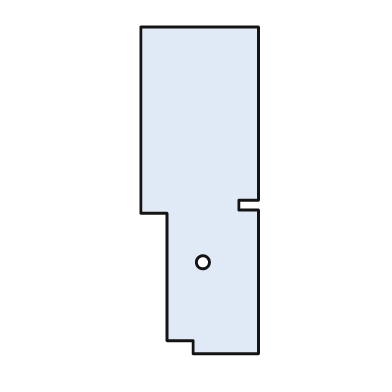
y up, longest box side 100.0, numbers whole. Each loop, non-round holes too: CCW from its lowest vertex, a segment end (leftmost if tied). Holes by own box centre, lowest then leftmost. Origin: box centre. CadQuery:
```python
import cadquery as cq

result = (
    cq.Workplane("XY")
    .moveTo(-2.0, -50.0)
    .lineTo(18.0, -50.0)
    .lineTo(18.0, -6.0)
    .lineTo(12.0, -6.0)
    .lineTo(12.0, -3.0)
    .lineTo(18.0, -3.0)
    .lineTo(18.0, 50.0)
    .lineTo(-18.0, 50.0)
    .lineTo(-18.0, -7.0)
    .lineTo(-10.0, -7.0)
    .lineTo(-10.0, -46.0)
    .lineTo(-2.0, -46.0)
    .close()
    .moveTo(1.0, -22.0)
    .circle(2.0)
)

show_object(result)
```